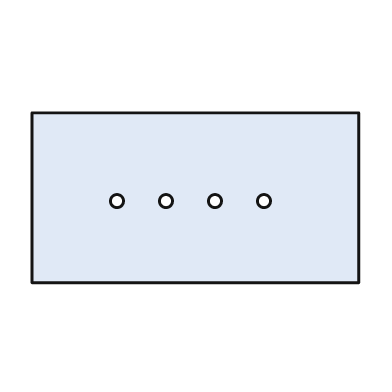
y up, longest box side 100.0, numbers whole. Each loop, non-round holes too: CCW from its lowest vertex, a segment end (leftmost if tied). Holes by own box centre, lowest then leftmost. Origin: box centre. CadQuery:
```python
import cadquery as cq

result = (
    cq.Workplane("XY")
    .moveTo(-50.0, -26.0)
    .lineTo(50.0, -26.0)
    .lineTo(50.0, 26.0)
    .lineTo(-50.0, 26.0)
    .close()
    .moveTo(-24.0, -1.0)
    .circle(2.0)
    .moveTo(-9.0, -1.0)
    .circle(2.0)
    .moveTo(6.0, -1.0)
    .circle(2.0)
    .moveTo(21.0, -1.0)
    .circle(2.0)
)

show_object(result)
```